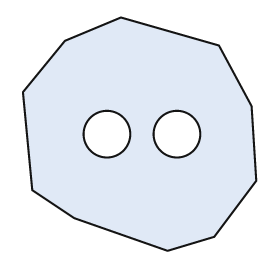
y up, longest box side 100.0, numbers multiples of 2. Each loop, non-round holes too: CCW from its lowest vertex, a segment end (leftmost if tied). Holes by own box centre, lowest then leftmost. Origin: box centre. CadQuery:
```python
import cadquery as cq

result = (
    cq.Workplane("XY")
    .moveTo(12.0, -50.0)
    .lineTo(32.0, -44.0)
    .lineTo(50.0, -20.0)
    .lineTo(48.0, 12.0)
    .lineTo(34.0, 38.0)
    .lineTo(-8.0, 50.0)
    .lineTo(-32.0, 40.0)
    .lineTo(-50.0, 18.0)
    .lineTo(-46.0, -24.0)
    .lineTo(-28.0, -36.0)
    .close()
    .moveTo(-14.0, 0.0)
    .circle(10.0)
    .moveTo(16.0, 0.0)
    .circle(10.0)
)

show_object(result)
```